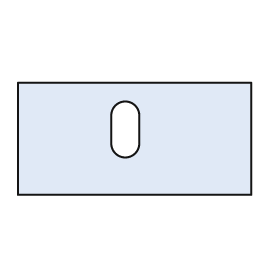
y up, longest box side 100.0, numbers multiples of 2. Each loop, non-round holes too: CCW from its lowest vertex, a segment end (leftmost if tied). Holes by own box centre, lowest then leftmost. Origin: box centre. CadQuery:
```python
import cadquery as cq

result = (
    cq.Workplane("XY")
    .moveTo(-50.0, -24.0)
    .lineTo(50.0, -24.0)
    .lineTo(50.0, 24.0)
    .lineTo(-50.0, 24.0)
    .close()
    .moveTo(-10.0, -2.0)
    .threePointArc((-4.0, -8.0), (2.0, -2.0))
    .lineTo(2.0, 10.0)
    .threePointArc((-4.0, 16.0), (-10.0, 10.0))
    .close()
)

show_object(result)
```